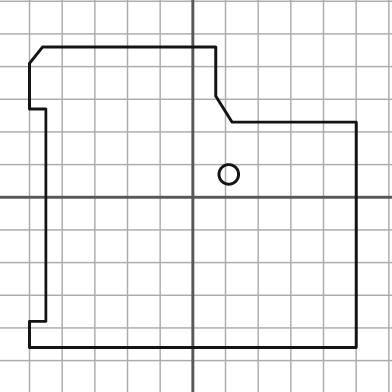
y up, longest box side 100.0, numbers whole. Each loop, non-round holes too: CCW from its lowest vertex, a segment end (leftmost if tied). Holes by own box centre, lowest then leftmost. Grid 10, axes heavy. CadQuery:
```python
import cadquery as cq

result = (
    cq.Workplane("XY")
    .moveTo(-50.0, -46.0)
    .lineTo(50.0, -46.0)
    .lineTo(50.0, 23.0)
    .lineTo(12.0, 23.0)
    .lineTo(7.0, 31.0)
    .lineTo(7.0, 46.0)
    .lineTo(-46.0, 46.0)
    .lineTo(-50.0, 41.0)
    .lineTo(-50.0, 27.0)
    .lineTo(-45.0, 27.0)
    .lineTo(-45.0, -38.0)
    .lineTo(-50.0, -38.0)
    .close()
    .moveTo(11.0, 7.0)
    .circle(3.0)
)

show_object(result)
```